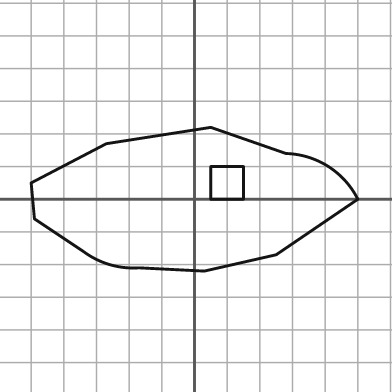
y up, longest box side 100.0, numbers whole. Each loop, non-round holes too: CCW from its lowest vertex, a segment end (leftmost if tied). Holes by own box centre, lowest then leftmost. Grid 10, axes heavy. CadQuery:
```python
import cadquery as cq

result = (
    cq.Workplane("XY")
    .moveTo(3.0, -22.0)
    .lineTo(25.0, -17.0)
    .lineTo(50.0, 0.0)
    .threePointArc((41.0, 10.0), (28.0, 14.0))
    .lineTo(5.0, 22.0)
    .lineTo(-27.0, 17.0)
    .lineTo(-50.0, 5.0)
    .lineTo(-49.0, -6.0)
    .lineTo(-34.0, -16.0)
    .threePointArc((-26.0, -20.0), (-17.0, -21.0))
    .close()
    .moveTo(5.0, 0.0)
    .lineTo(15.0, 0.0)
    .lineTo(15.0, 10.0)
    .lineTo(5.0, 10.0)
    .close()
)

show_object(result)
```